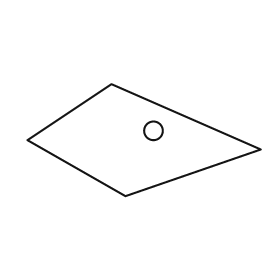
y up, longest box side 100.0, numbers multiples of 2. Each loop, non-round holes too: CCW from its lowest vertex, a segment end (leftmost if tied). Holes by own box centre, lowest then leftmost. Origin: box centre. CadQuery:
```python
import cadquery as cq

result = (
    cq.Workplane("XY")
    .moveTo(-8.0, -24.0)
    .lineTo(50.0, -4.0)
    .lineTo(-14.0, 24.0)
    .lineTo(-50.0, 0.0)
    .close()
    .moveTo(4.0, 4.0)
    .circle(4.0)
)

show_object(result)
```